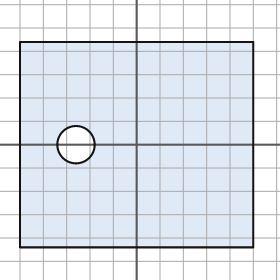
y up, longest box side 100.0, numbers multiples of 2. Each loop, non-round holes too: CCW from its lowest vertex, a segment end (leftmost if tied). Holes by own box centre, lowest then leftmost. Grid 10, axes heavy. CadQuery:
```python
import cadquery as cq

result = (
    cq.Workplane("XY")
    .moveTo(-50.0, -44.0)
    .lineTo(50.0, -44.0)
    .lineTo(50.0, 44.0)
    .lineTo(-50.0, 44.0)
    .close()
    .moveTo(-26.0, 0.0)
    .circle(8.0)
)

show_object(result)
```